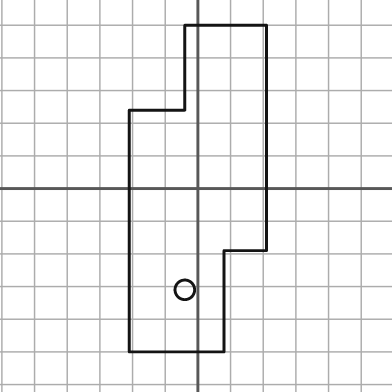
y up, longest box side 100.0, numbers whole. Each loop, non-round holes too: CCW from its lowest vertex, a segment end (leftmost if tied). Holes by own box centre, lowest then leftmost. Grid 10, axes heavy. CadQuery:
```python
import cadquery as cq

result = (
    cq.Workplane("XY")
    .moveTo(-21.0, -50.0)
    .lineTo(8.0, -50.0)
    .lineTo(8.0, -19.0)
    .lineTo(21.0, -19.0)
    .lineTo(21.0, 50.0)
    .lineTo(-4.0, 50.0)
    .lineTo(-4.0, 24.0)
    .lineTo(-21.0, 24.0)
    .close()
    .moveTo(-4.0, -31.0)
    .circle(3.0)
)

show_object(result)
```